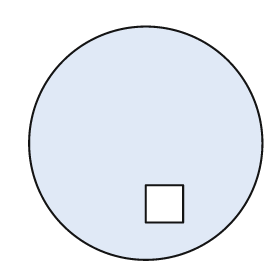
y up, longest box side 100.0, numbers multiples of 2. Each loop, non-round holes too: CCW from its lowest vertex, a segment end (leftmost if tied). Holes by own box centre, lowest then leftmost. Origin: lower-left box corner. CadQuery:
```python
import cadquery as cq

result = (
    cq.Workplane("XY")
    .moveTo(50.0, 50.0)
    .circle(50.0)
    .moveTo(50.0, 16.0)
    .lineTo(66.0, 16.0)
    .lineTo(66.0, 32.0)
    .lineTo(50.0, 32.0)
    .close()
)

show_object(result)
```